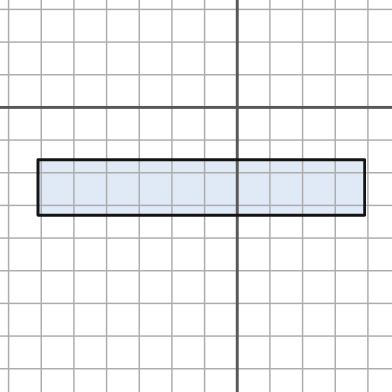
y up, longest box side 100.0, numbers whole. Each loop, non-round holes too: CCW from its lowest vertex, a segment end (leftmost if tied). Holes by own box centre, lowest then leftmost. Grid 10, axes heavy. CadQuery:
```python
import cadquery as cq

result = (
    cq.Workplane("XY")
    .moveTo(-61.0, -33.0)
    .lineTo(39.0, -33.0)
    .lineTo(39.0, -16.0)
    .lineTo(-61.0, -16.0)
    .close()
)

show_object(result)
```